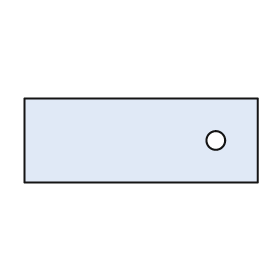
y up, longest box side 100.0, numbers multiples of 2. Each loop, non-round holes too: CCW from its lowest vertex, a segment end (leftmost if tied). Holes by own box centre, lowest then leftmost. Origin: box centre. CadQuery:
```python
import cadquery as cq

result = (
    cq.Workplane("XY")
    .moveTo(-50.0, -18.0)
    .lineTo(50.0, -18.0)
    .lineTo(50.0, 18.0)
    .lineTo(-50.0, 18.0)
    .close()
    .moveTo(32.0, 0.0)
    .circle(4.0)
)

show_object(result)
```